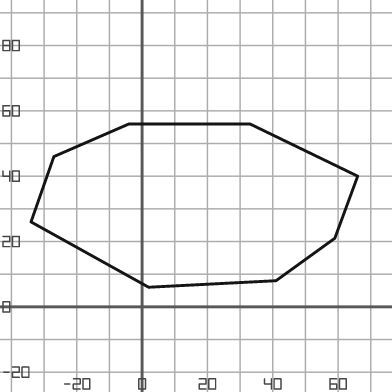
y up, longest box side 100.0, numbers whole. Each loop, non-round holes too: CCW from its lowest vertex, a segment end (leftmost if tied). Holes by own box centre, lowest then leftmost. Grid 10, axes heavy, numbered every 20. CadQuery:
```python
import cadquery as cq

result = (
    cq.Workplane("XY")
    .moveTo(2.0, 6.0)
    .lineTo(41.0, 8.0)
    .lineTo(59.0, 21.0)
    .lineTo(66.0, 40.0)
    .lineTo(33.0, 56.0)
    .lineTo(-4.0, 56.0)
    .lineTo(-27.0, 46.0)
    .lineTo(-34.0, 26.0)
    .close()
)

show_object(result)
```